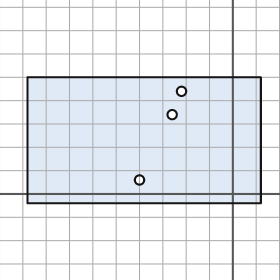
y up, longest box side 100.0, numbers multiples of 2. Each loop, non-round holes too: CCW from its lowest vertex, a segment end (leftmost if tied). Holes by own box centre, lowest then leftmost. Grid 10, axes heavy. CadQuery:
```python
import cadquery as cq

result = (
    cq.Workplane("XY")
    .moveTo(-88.0, -4.0)
    .lineTo(12.0, -4.0)
    .lineTo(12.0, 50.0)
    .lineTo(-88.0, 50.0)
    .close()
    .moveTo(-40.0, 6.0)
    .circle(2.0)
    .moveTo(-26.0, 34.0)
    .circle(2.0)
    .moveTo(-22.0, 44.0)
    .circle(2.0)
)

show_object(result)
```